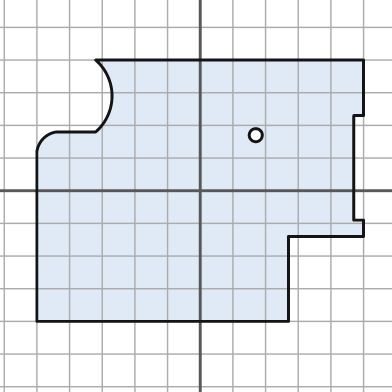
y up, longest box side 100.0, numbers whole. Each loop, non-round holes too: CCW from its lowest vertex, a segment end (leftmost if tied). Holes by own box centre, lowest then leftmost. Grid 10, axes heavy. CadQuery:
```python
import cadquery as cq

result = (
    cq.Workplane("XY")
    .moveTo(-50.0, -40.0)
    .lineTo(27.0, -40.0)
    .lineTo(27.0, -14.0)
    .lineTo(50.0, -14.0)
    .lineTo(50.0, -9.0)
    .lineTo(47.0, -9.0)
    .lineTo(47.0, 23.0)
    .lineTo(50.0, 23.0)
    .lineTo(50.0, 40.0)
    .lineTo(-32.0, 40.0)
    .threePointArc((-27.0, 29.0), (-32.0, 18.0))
    .lineTo(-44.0, 18.0)
    .threePointArc((-48.0, 16.0), (-50.0, 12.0))
    .close()
    .moveTo(17.0, 17.0)
    .circle(2.0)
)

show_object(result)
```